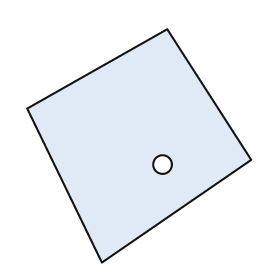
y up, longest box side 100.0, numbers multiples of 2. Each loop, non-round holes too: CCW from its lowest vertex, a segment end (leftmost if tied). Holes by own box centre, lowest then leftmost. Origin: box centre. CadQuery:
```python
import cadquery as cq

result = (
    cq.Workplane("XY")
    .moveTo(-16.0, -50.0)
    .lineTo(48.0, -6.0)
    .lineTo(12.0, 50.0)
    .lineTo(-48.0, 16.0)
    .close()
    .moveTo(10.0, -8.0)
    .circle(4.0)
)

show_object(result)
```